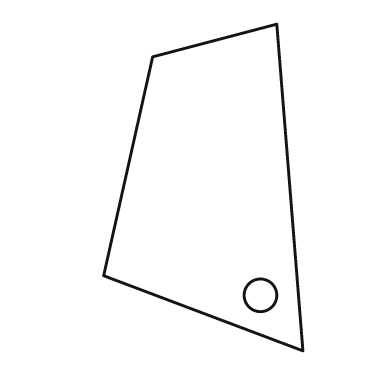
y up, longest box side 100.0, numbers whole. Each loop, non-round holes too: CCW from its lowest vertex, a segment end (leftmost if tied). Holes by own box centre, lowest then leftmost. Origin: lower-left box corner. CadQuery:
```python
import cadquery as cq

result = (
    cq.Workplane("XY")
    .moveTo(61.0, 0.0)
    .lineTo(53.0, 100.0)
    .lineTo(15.0, 90.0)
    .lineTo(0.0, 23.0)
    .close()
    .moveTo(48.0, 17.0)
    .circle(5.0)
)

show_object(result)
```